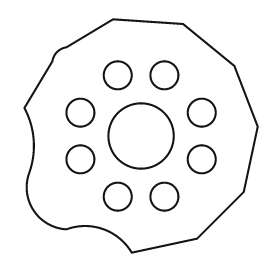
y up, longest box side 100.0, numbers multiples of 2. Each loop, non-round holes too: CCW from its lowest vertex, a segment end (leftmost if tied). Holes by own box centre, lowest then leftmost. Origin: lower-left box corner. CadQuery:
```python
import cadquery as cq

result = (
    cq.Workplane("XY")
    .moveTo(46.0, 0.0)
    .lineTo(74.0, 6.0)
    .lineTo(94.0, 26.0)
    .lineTo(100.0, 54.0)
    .lineTo(90.0, 80.0)
    .lineTo(68.0, 98.0)
    .lineTo(38.0, 100.0)
    .lineTo(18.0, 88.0)
    .threePointArc((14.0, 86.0), (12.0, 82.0))
    .lineTo(0.0, 62.0)
    .threePointArc((4.0, 48.0), (2.0, 34.0))
    .threePointArc((4.0, 18.0), (18.0, 10.0))
    .threePointArc((34.0, 10.0), (46.0, 0.0))
    .close()
    .moveTo(40.0, 24.0)
    .circle(6.0)
    .moveTo(60.0, 24.0)
    .circle(6.0)
    .moveTo(24.0, 40.0)
    .circle(6.0)
    .moveTo(76.0, 40.0)
    .circle(6.0)
    .moveTo(50.0, 50.0)
    .circle(14.0)
    .moveTo(24.0, 60.0)
    .circle(6.0)
    .moveTo(76.0, 60.0)
    .circle(6.0)
    .moveTo(40.0, 76.0)
    .circle(6.0)
    .moveTo(60.0, 76.0)
    .circle(6.0)
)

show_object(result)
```